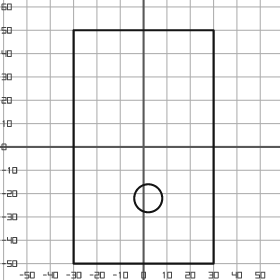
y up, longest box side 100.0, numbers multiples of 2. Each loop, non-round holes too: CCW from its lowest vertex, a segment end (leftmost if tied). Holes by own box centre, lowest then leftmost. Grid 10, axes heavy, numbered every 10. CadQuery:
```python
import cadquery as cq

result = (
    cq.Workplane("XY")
    .moveTo(-30.0, -50.0)
    .lineTo(30.0, -50.0)
    .lineTo(30.0, 50.0)
    .lineTo(-30.0, 50.0)
    .close()
    .moveTo(2.0, -22.0)
    .circle(6.0)
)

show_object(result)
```